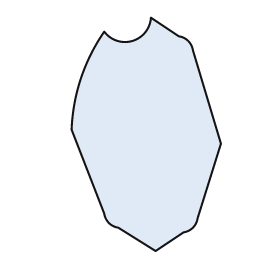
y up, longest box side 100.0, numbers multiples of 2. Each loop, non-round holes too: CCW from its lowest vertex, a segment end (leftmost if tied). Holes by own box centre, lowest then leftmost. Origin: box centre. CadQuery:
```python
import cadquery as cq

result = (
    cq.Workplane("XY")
    .moveTo(4.0, -50.0)
    .lineTo(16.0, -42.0)
    .threePointArc((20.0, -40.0), (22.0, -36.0))
    .lineTo(32.0, -4.0)
    .lineTo(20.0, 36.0)
    .threePointArc((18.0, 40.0), (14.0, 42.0))
    .lineTo(2.0, 50.0)
    .threePointArc((-6.0, 40.0), (-18.0, 44.0))
    .threePointArc((-28.0, 24.0), (-32.0, 2.0))
    .lineTo(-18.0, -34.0)
    .threePointArc((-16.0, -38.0), (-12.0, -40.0))
    .close()
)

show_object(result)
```